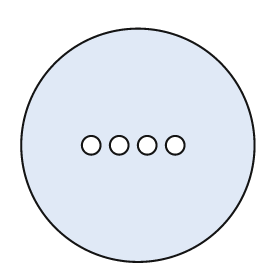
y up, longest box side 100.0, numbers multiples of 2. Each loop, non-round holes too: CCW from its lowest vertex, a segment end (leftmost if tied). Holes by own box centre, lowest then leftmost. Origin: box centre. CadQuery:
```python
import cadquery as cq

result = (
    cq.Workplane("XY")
    .moveTo(0.0, 0.0)
    .circle(50.0)
    .moveTo(-20.0, 0.0)
    .circle(4.0)
    .moveTo(-8.0, 0.0)
    .circle(4.0)
    .moveTo(4.0, 0.0)
    .circle(4.0)
    .moveTo(16.0, 0.0)
    .circle(4.0)
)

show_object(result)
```